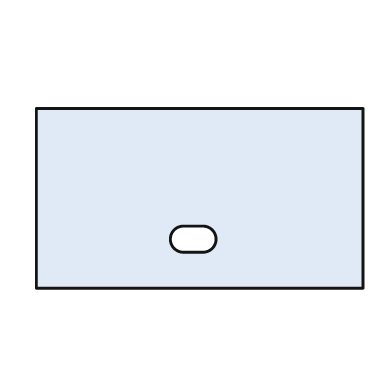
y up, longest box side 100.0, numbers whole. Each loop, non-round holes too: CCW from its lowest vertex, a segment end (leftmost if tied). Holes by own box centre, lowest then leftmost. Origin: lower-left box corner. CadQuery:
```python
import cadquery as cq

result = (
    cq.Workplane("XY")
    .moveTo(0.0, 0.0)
    .lineTo(100.0, 0.0)
    .lineTo(100.0, 55.0)
    .lineTo(0.0, 55.0)
    .close()
    .moveTo(45.0, 11.0)
    .lineTo(51.0, 11.0)
    .threePointArc((55.0, 15.0), (51.0, 19.0))
    .lineTo(45.0, 19.0)
    .threePointArc((41.0, 15.0), (45.0, 11.0))
    .close()
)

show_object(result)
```